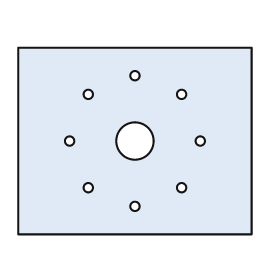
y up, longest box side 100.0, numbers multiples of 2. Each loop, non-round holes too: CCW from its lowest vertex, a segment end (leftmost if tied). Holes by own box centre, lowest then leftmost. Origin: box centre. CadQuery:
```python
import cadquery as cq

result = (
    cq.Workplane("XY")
    .moveTo(-50.0, -40.0)
    .lineTo(50.0, -40.0)
    .lineTo(50.0, 40.0)
    .lineTo(-50.0, 40.0)
    .close()
    .moveTo(0.0, -28.0)
    .circle(2.0)
    .moveTo(-20.0, -20.0)
    .circle(2.0)
    .moveTo(20.0, -20.0)
    .circle(2.0)
    .moveTo(-28.0, 0.0)
    .circle(2.0)
    .moveTo(0.0, 0.0)
    .circle(8.0)
    .moveTo(28.0, 0.0)
    .circle(2.0)
    .moveTo(-20.0, 20.0)
    .circle(2.0)
    .moveTo(20.0, 20.0)
    .circle(2.0)
    .moveTo(0.0, 28.0)
    .circle(2.0)
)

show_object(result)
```